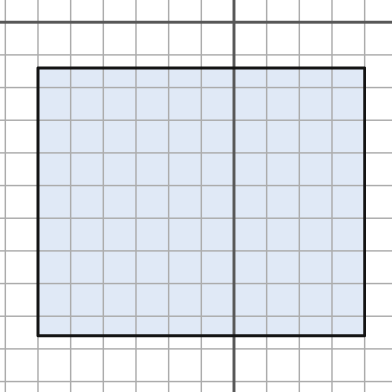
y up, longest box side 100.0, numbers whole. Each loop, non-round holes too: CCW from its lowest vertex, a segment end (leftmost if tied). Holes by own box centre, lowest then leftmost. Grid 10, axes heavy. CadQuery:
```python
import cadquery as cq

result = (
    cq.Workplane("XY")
    .moveTo(-60.0, -96.0)
    .lineTo(40.0, -96.0)
    .lineTo(40.0, -14.0)
    .lineTo(-60.0, -14.0)
    .close()
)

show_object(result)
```